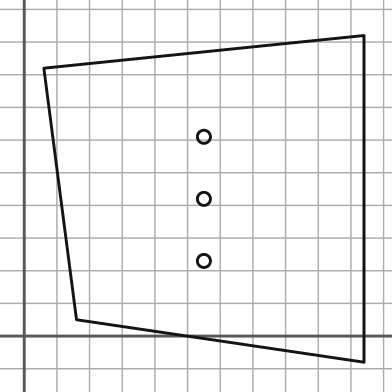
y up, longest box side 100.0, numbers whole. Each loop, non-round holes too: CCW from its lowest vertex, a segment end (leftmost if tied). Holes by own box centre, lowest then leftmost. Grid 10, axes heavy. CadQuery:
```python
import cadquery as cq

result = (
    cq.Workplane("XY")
    .moveTo(104.0, -8.0)
    .lineTo(104.0, 92.0)
    .lineTo(6.0, 82.0)
    .lineTo(16.0, 5.0)
    .close()
    .moveTo(55.0, 23.0)
    .circle(2.0)
    .moveTo(55.0, 42.0)
    .circle(2.0)
    .moveTo(55.0, 61.0)
    .circle(2.0)
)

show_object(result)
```